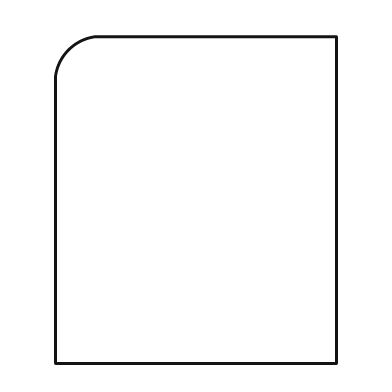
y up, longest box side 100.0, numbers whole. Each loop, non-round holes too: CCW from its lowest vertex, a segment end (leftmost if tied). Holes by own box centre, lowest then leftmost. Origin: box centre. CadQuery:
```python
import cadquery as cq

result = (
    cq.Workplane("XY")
    .moveTo(-43.0, -50.0)
    .lineTo(43.0, -50.0)
    .lineTo(43.0, 50.0)
    .lineTo(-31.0, 50.0)
    .threePointArc((-39.0, 46.0), (-43.0, 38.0))
    .close()
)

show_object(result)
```